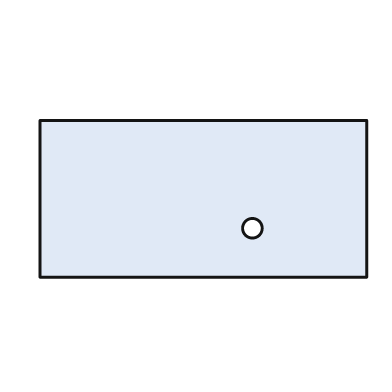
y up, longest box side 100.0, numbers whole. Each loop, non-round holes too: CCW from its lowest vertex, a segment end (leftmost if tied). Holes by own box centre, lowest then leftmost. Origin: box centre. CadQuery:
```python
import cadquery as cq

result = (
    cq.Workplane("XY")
    .moveTo(-50.0, -24.0)
    .lineTo(50.0, -24.0)
    .lineTo(50.0, 24.0)
    .lineTo(-50.0, 24.0)
    .close()
    .moveTo(15.0, -9.0)
    .circle(3.0)
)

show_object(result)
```